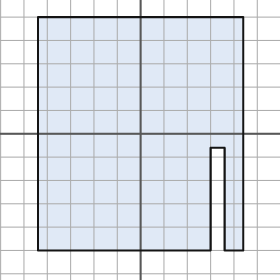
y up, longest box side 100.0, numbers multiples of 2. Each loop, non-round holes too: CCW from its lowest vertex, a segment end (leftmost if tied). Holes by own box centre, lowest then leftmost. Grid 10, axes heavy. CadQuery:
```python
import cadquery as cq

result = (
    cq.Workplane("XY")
    .moveTo(-44.0, -50.0)
    .lineTo(30.0, -50.0)
    .lineTo(30.0, -6.0)
    .lineTo(36.0, -6.0)
    .lineTo(36.0, -50.0)
    .lineTo(44.0, -50.0)
    .lineTo(44.0, 50.0)
    .lineTo(-44.0, 50.0)
    .close()
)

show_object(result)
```